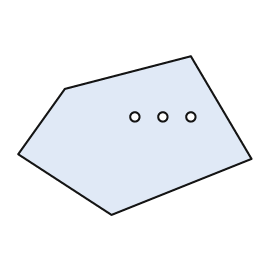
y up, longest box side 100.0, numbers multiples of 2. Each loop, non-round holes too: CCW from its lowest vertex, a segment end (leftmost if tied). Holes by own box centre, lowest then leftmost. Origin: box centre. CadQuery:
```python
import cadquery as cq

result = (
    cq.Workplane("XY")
    .moveTo(-10.0, -34.0)
    .lineTo(50.0, -10.0)
    .lineTo(24.0, 34.0)
    .lineTo(-30.0, 20.0)
    .lineTo(-50.0, -8.0)
    .close()
    .moveTo(0.0, 8.0)
    .circle(2.0)
    .moveTo(12.0, 8.0)
    .circle(2.0)
    .moveTo(24.0, 8.0)
    .circle(2.0)
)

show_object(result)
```